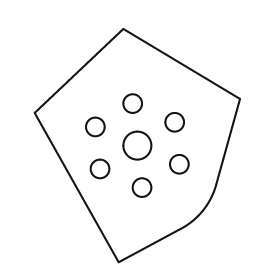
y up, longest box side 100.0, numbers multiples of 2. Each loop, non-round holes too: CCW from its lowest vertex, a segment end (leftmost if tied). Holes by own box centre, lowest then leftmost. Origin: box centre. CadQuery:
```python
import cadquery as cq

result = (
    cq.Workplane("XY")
    .moveTo(-8.0, -50.0)
    .lineTo(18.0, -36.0)
    .threePointArc((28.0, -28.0), (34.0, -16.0))
    .lineTo(44.0, 20.0)
    .lineTo(-6.0, 50.0)
    .lineTo(-44.0, 14.0)
    .close()
    .moveTo(2.0, -18.0)
    .circle(4.0)
    .moveTo(-16.0, -10.0)
    .circle(4.0)
    .moveTo(18.0, -8.0)
    .circle(4.0)
    .moveTo(0.0, 0.0)
    .circle(6.0)
    .moveTo(-18.0, 8.0)
    .circle(4.0)
    .moveTo(16.0, 10.0)
    .circle(4.0)
    .moveTo(-2.0, 18.0)
    .circle(4.0)
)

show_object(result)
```